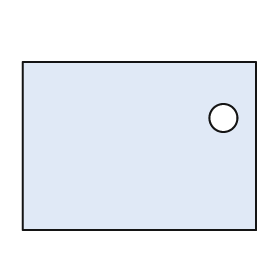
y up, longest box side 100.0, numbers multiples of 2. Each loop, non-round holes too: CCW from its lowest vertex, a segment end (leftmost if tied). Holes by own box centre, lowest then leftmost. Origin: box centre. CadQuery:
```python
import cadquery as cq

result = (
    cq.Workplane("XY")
    .moveTo(-50.0, -36.0)
    .lineTo(50.0, -36.0)
    .lineTo(50.0, 36.0)
    .lineTo(-50.0, 36.0)
    .close()
    .moveTo(36.0, 12.0)
    .circle(6.0)
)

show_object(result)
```